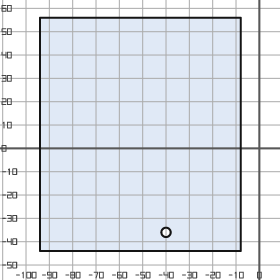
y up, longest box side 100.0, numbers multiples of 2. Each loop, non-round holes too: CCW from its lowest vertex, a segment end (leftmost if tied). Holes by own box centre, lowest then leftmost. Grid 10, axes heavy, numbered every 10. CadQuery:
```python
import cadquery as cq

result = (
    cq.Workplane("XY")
    .moveTo(-94.0, -44.0)
    .lineTo(-8.0, -44.0)
    .lineTo(-8.0, 56.0)
    .lineTo(-94.0, 56.0)
    .close()
    .moveTo(-40.0, -36.0)
    .circle(2.0)
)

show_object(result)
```